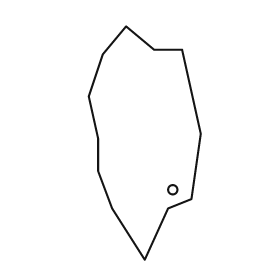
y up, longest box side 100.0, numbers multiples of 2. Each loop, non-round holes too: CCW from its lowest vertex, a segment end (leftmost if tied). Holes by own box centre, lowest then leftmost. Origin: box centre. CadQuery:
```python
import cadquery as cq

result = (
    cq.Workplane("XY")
    .moveTo(0.0, -50.0)
    .lineTo(10.0, -28.0)
    .lineTo(20.0, -24.0)
    .lineTo(24.0, 4.0)
    .lineTo(16.0, 40.0)
    .lineTo(4.0, 40.0)
    .lineTo(-8.0, 50.0)
    .lineTo(-18.0, 38.0)
    .lineTo(-24.0, 20.0)
    .lineTo(-20.0, 2.0)
    .lineTo(-20.0, -12.0)
    .lineTo(-14.0, -28.0)
    .close()
    .moveTo(12.0, -20.0)
    .circle(2.0)
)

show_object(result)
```